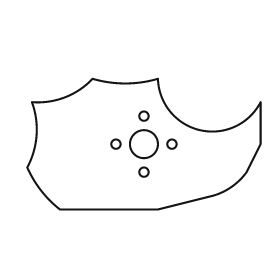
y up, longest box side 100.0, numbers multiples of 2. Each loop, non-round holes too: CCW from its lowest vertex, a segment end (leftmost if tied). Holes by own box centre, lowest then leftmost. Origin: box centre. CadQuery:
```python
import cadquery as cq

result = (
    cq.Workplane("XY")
    .moveTo(-36.0, -28.0)
    .lineTo(6.0, -28.0)
    .lineTo(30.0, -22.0)
    .threePointArc((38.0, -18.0), (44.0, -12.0))
    .lineTo(50.0, 0.0)
    .lineTo(50.0, 18.0)
    .threePointArc((24.0, 6.0), (6.0, 28.0))
    .threePointArc((-8.0, 26.0), (-22.0, 28.0))
    .threePointArc((-34.0, 20.0), (-48.0, 18.0))
    .threePointArc((-46.0, 4.0), (-50.0, -10.0))
    .threePointArc((-44.0, -20.0), (-36.0, -28.0))
    .close()
    .moveTo(0.0, -12.0)
    .circle(2.0)
    .moveTo(-12.0, 0.0)
    .circle(2.0)
    .moveTo(0.0, 0.0)
    .circle(6.0)
    .moveTo(12.0, 0.0)
    .circle(2.0)
    .moveTo(0.0, 12.0)
    .circle(2.0)
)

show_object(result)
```